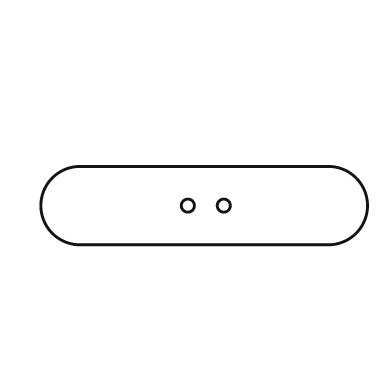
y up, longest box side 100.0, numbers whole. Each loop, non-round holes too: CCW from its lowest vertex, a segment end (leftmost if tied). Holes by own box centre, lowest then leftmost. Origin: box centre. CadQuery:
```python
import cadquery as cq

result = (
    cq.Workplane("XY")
    .moveTo(-38.0, -12.0)
    .lineTo(38.0, -12.0)
    .threePointArc((50.0, 0.0), (38.0, 12.0))
    .lineTo(-38.0, 12.0)
    .threePointArc((-50.0, 0.0), (-38.0, -12.0))
    .close()
    .moveTo(-5.0, 0.0)
    .circle(2.0)
    .moveTo(6.0, 0.0)
    .circle(2.0)
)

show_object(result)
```